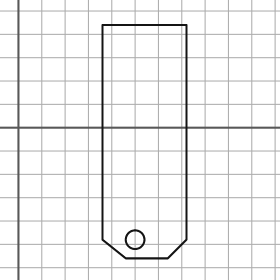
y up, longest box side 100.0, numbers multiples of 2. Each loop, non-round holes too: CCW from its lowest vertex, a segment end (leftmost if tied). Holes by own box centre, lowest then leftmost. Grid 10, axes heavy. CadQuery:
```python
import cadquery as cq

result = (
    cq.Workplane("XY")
    .moveTo(46.0, -56.0)
    .lineTo(64.0, -56.0)
    .lineTo(72.0, -48.0)
    .lineTo(72.0, 44.0)
    .lineTo(36.0, 44.0)
    .lineTo(36.0, -48.0)
    .close()
    .moveTo(50.0, -48.0)
    .circle(4.0)
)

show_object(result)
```